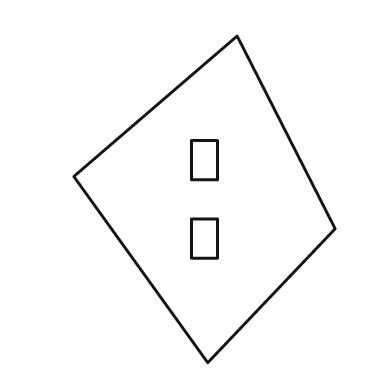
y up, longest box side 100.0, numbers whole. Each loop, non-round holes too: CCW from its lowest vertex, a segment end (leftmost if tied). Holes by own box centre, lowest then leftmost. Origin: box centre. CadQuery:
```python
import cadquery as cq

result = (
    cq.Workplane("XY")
    .moveTo(1.0, -50.0)
    .lineTo(40.0, -9.0)
    .lineTo(10.0, 50.0)
    .lineTo(-40.0, 7.0)
    .close()
    .moveTo(-4.0, -18.0)
    .lineTo(4.0, -18.0)
    .lineTo(4.0, -6.0)
    .lineTo(-4.0, -6.0)
    .close()
    .moveTo(-4.0, 6.0)
    .lineTo(4.0, 6.0)
    .lineTo(4.0, 18.0)
    .lineTo(-4.0, 18.0)
    .close()
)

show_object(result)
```